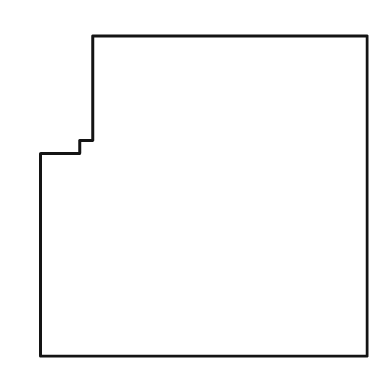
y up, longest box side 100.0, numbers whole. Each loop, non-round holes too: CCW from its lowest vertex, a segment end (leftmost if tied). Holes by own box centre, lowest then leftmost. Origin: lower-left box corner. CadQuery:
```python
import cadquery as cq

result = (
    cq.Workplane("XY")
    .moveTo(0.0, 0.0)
    .lineTo(100.0, 0.0)
    .lineTo(100.0, 98.0)
    .lineTo(16.0, 98.0)
    .lineTo(16.0, 66.0)
    .lineTo(12.0, 66.0)
    .lineTo(12.0, 62.0)
    .lineTo(0.0, 62.0)
    .close()
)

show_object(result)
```